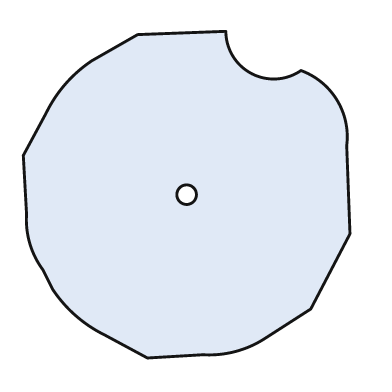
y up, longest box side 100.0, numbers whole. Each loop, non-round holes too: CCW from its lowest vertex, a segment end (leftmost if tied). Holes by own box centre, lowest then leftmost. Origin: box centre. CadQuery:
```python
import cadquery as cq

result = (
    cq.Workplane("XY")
    .moveTo(-12.0, -50.0)
    .lineTo(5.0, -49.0)
    .threePointArc((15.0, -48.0), (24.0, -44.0))
    .lineTo(38.0, -35.0)
    .lineTo(50.0, -12.0)
    .lineTo(49.0, 15.0)
    .threePointArc((46.0, 29.0), (35.0, 38.0))
    .threePointArc((20.0, 37.0), (12.0, 50.0))
    .lineTo(-15.0, 49.0)
    .lineTo(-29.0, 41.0)
    .threePointArc((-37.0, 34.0), (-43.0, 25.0))
    .lineTo(-50.0, 12.0)
    .lineTo(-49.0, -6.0)
    .threePointArc((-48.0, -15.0), (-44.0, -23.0))
    .lineTo(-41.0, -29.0)
    .threePointArc((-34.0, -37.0), (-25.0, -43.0))
    .close()
    .moveTo(0.0, 0.0)
    .circle(3.0)
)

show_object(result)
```